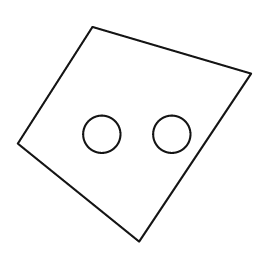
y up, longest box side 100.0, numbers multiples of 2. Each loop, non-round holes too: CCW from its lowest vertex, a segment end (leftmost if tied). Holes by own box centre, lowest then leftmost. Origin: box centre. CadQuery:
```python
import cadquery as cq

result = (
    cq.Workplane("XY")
    .moveTo(2.0, -46.0)
    .lineTo(50.0, 26.0)
    .lineTo(-18.0, 46.0)
    .lineTo(-50.0, -4.0)
    .close()
    .moveTo(-14.0, 0.0)
    .circle(8.0)
    .moveTo(16.0, 0.0)
    .circle(8.0)
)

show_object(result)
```